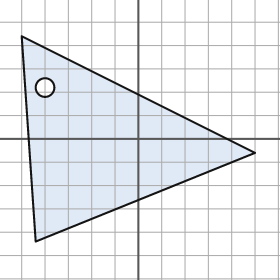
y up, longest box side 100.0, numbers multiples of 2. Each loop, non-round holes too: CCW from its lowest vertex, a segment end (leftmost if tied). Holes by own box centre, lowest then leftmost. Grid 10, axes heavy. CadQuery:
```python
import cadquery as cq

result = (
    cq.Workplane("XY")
    .moveTo(-44.0, -44.0)
    .lineTo(50.0, -6.0)
    .lineTo(-50.0, 44.0)
    .close()
    .moveTo(-40.0, 22.0)
    .circle(4.0)
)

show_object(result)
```